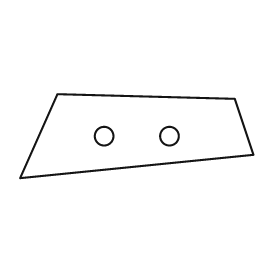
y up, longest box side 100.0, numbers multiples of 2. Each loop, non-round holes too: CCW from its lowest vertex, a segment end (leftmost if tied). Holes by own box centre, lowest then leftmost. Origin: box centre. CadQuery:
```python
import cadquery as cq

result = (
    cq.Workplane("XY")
    .moveTo(-50.0, -18.0)
    .lineTo(50.0, -8.0)
    .lineTo(42.0, 16.0)
    .lineTo(-34.0, 18.0)
    .close()
    .moveTo(-14.0, 0.0)
    .circle(4.0)
    .moveTo(14.0, 0.0)
    .circle(4.0)
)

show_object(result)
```